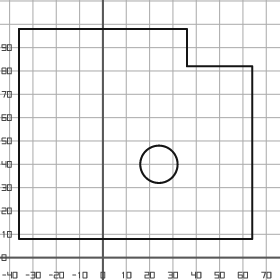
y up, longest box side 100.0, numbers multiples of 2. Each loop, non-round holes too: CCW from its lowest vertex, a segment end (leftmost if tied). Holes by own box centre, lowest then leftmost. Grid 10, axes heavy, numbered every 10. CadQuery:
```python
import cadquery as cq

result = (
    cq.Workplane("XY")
    .moveTo(-36.0, 8.0)
    .lineTo(64.0, 8.0)
    .lineTo(64.0, 82.0)
    .lineTo(36.0, 82.0)
    .lineTo(36.0, 98.0)
    .lineTo(-36.0, 98.0)
    .close()
    .moveTo(24.0, 40.0)
    .circle(8.0)
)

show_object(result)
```